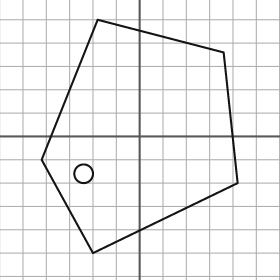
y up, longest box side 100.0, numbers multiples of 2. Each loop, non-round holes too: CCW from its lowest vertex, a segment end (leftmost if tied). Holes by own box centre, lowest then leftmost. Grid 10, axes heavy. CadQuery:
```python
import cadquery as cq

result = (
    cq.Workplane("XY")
    .moveTo(-20.0, -50.0)
    .lineTo(42.0, -20.0)
    .lineTo(36.0, 36.0)
    .lineTo(-18.0, 50.0)
    .lineTo(-42.0, -10.0)
    .close()
    .moveTo(-24.0, -16.0)
    .circle(4.0)
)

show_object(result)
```